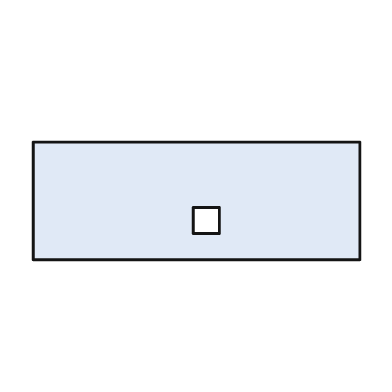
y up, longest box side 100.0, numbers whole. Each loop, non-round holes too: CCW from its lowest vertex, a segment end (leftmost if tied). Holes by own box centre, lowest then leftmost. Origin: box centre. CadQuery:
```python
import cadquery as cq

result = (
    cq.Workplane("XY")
    .moveTo(-50.0, -18.0)
    .lineTo(50.0, -18.0)
    .lineTo(50.0, 18.0)
    .lineTo(-50.0, 18.0)
    .close()
    .moveTo(-1.0, -10.0)
    .lineTo(7.0, -10.0)
    .lineTo(7.0, -2.0)
    .lineTo(-1.0, -2.0)
    .close()
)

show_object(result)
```